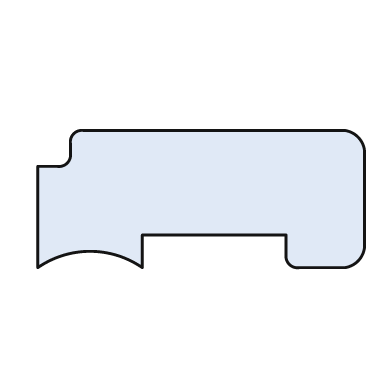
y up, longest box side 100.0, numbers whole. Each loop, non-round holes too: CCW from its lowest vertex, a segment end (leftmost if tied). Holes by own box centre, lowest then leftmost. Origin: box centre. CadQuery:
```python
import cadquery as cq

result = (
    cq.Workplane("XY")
    .moveTo(-50.0, -21.0)
    .threePointArc((-34.0, -16.0), (-18.0, -21.0))
    .lineTo(-18.0, -11.0)
    .lineTo(26.0, -11.0)
    .lineTo(26.0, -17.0)
    .threePointArc((27.0, -20.0), (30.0, -21.0))
    .lineTo(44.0, -21.0)
    .threePointArc((48.0, -19.0), (50.0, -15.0))
    .lineTo(50.0, 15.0)
    .threePointArc((48.0, 19.0), (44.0, 21.0))
    .lineTo(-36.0, 21.0)
    .threePointArc((-39.0, 20.0), (-40.0, 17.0))
    .lineTo(-40.0, 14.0)
    .threePointArc((-41.0, 11.0), (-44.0, 10.0))
    .lineTo(-50.0, 10.0)
    .close()
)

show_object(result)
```